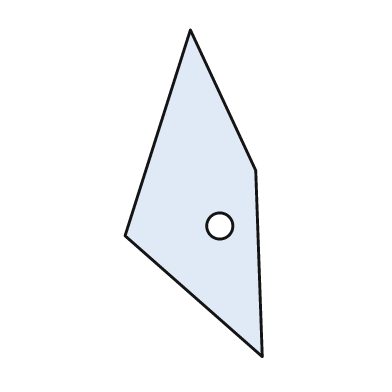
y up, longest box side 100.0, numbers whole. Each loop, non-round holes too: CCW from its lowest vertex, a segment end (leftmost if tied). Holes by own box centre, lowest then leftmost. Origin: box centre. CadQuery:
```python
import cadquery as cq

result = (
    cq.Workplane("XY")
    .moveTo(21.0, -50.0)
    .lineTo(19.0, 7.0)
    .lineTo(-1.0, 50.0)
    .lineTo(-21.0, -13.0)
    .close()
    .moveTo(8.0, -10.0)
    .circle(4.0)
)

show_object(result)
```